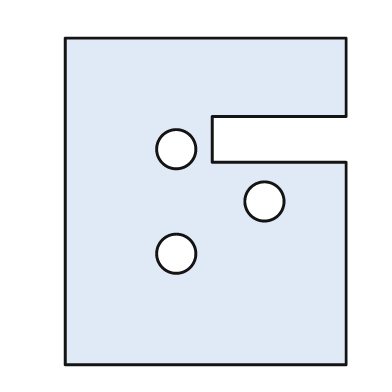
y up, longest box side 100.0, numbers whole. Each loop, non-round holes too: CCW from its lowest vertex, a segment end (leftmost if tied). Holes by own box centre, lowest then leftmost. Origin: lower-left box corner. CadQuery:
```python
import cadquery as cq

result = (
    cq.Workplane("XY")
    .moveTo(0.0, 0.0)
    .lineTo(86.0, 0.0)
    .lineTo(86.0, 62.0)
    .lineTo(45.0, 62.0)
    .lineTo(45.0, 76.0)
    .lineTo(86.0, 76.0)
    .lineTo(86.0, 100.0)
    .lineTo(0.0, 100.0)
    .close()
    .moveTo(34.0, 34.0)
    .circle(6.0)
    .moveTo(61.0, 50.0)
    .circle(6.0)
    .moveTo(34.0, 66.0)
    .circle(6.0)
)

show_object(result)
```